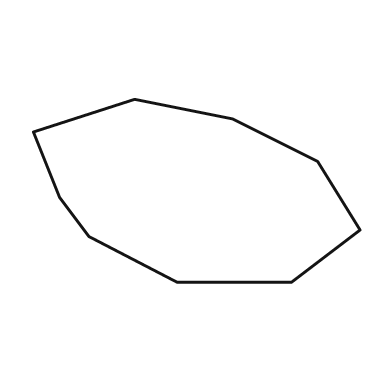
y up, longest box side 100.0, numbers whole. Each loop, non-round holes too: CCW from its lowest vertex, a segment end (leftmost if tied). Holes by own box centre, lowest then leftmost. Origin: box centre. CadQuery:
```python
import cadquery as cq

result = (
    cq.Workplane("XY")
    .moveTo(-6.0, -28.0)
    .lineTo(29.0, -28.0)
    .lineTo(50.0, -12.0)
    .lineTo(37.0, 9.0)
    .lineTo(11.0, 22.0)
    .lineTo(-19.0, 28.0)
    .lineTo(-50.0, 18.0)
    .lineTo(-42.0, -2.0)
    .lineTo(-33.0, -14.0)
    .close()
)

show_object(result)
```